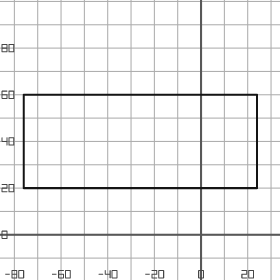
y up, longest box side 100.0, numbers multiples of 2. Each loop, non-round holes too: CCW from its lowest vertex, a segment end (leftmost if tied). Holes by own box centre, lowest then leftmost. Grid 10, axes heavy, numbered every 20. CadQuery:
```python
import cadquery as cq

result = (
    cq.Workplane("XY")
    .moveTo(-76.0, 20.0)
    .lineTo(24.0, 20.0)
    .lineTo(24.0, 60.0)
    .lineTo(-76.0, 60.0)
    .close()
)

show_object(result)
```